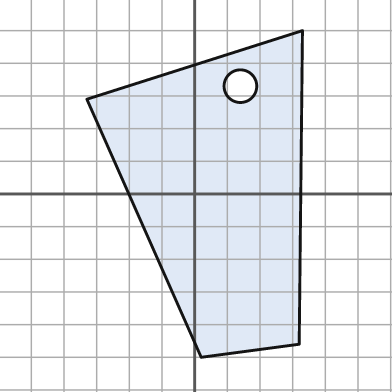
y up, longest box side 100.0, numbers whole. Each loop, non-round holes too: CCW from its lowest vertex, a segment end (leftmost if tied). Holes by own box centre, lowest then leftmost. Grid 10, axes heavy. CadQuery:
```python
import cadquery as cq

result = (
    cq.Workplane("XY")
    .moveTo(2.0, -50.0)
    .lineTo(32.0, -46.0)
    .lineTo(33.0, 50.0)
    .lineTo(-33.0, 29.0)
    .close()
    .moveTo(14.0, 33.0)
    .circle(5.0)
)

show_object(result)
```